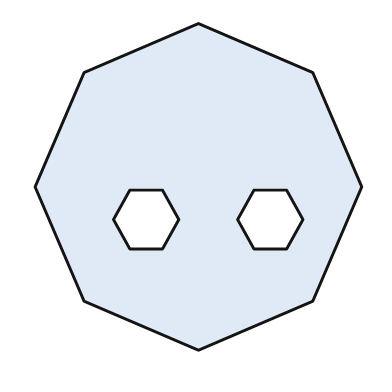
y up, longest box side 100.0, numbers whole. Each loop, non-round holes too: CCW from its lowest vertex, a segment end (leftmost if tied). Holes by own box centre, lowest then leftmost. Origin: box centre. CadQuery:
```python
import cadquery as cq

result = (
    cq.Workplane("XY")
    .moveTo(0.0, -50.0)
    .lineTo(35.0, -35.0)
    .lineTo(50.0, 0.0)
    .lineTo(35.0, 35.0)
    .lineTo(0.0, 50.0)
    .lineTo(-35.0, 35.0)
    .lineTo(-50.0, 0.0)
    .lineTo(-35.0, -35.0)
    .close()
    .moveTo(-21.0, -19.0)
    .lineTo(-11.0, -19.0)
    .lineTo(-6.0, -10.0)
    .lineTo(-11.0, -1.0)
    .lineTo(-21.0, -1.0)
    .lineTo(-26.0, -10.0)
    .close()
    .moveTo(17.0, -19.0)
    .lineTo(27.0, -19.0)
    .lineTo(32.0, -10.0)
    .lineTo(27.0, -1.0)
    .lineTo(17.0, -1.0)
    .lineTo(12.0, -10.0)
    .close()
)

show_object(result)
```